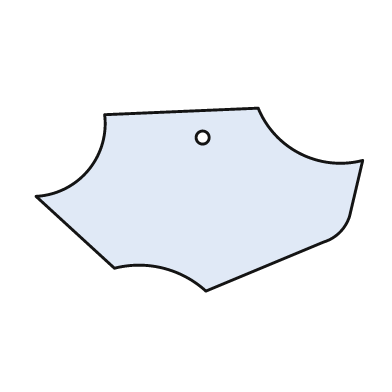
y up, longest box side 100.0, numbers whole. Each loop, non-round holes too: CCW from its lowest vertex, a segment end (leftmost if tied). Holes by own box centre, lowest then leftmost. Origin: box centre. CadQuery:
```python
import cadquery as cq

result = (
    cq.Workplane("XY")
    .moveTo(2.0, -28.0)
    .lineTo(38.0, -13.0)
    .threePointArc((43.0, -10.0), (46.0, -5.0))
    .lineTo(50.0, 12.0)
    .threePointArc((31.0, 14.0), (18.0, 28.0))
    .lineTo(-29.0, 26.0)
    .threePointArc((-34.0, 9.0), (-50.0, 1.0))
    .lineTo(-26.0, -21.0)
    .threePointArc((-11.0, -21.0), (2.0, -28.0))
    .close()
    .moveTo(1.0, 19.0)
    .circle(2.0)
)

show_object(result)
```